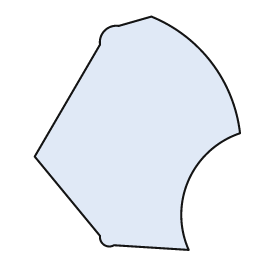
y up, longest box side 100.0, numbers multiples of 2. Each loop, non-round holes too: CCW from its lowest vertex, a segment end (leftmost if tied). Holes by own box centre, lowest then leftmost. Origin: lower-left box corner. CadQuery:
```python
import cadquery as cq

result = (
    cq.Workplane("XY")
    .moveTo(66.0, 0.0)
    .threePointArc((66.0, 30.0), (88.0, 50.0))
    .threePointArc((76.0, 80.0), (50.0, 100.0))
    .lineTo(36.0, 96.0)
    .threePointArc((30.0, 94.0), (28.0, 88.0))
    .lineTo(0.0, 40.0)
    .lineTo(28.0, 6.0)
    .threePointArc((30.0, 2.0), (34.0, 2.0))
    .close()
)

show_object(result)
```